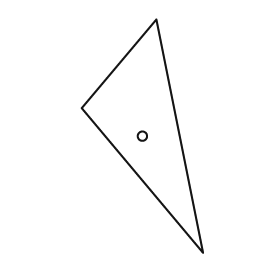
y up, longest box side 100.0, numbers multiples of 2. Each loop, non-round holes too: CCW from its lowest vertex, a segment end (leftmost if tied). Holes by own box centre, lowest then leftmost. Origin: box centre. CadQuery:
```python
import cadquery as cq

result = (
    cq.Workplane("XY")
    .moveTo(26.0, -50.0)
    .lineTo(6.0, 50.0)
    .lineTo(-26.0, 12.0)
    .close()
    .moveTo(0.0, 0.0)
    .circle(2.0)
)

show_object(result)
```